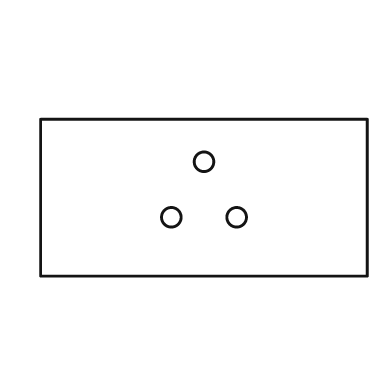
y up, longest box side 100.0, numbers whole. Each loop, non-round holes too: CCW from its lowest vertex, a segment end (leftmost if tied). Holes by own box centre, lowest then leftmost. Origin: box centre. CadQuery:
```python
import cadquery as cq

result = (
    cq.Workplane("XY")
    .moveTo(-50.0, -24.0)
    .lineTo(50.0, -24.0)
    .lineTo(50.0, 24.0)
    .lineTo(-50.0, 24.0)
    .close()
    .moveTo(-10.0, -6.0)
    .circle(3.0)
    .moveTo(10.0, -6.0)
    .circle(3.0)
    .moveTo(0.0, 11.0)
    .circle(3.0)
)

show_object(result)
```